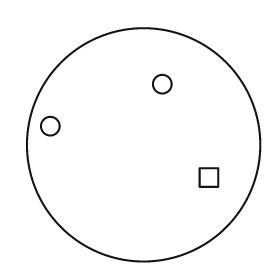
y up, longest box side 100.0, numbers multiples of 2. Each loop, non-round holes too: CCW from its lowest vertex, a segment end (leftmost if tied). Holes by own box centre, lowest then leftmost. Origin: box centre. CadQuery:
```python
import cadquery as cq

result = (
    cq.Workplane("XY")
    .moveTo(0.0, 0.0)
    .circle(50.0)
    .moveTo(24.0, -18.0)
    .lineTo(32.0, -18.0)
    .lineTo(32.0, -10.0)
    .lineTo(24.0, -10.0)
    .close()
    .moveTo(-40.0, 8.0)
    .circle(4.0)
    .moveTo(8.0, 26.0)
    .circle(4.0)
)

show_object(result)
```